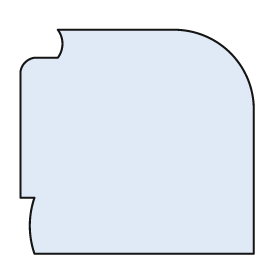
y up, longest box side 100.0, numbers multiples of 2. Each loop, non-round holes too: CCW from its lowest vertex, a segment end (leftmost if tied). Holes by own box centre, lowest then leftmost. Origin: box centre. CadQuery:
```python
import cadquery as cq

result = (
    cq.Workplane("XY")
    .moveTo(-44.0, -48.0)
    .lineTo(50.0, -48.0)
    .lineTo(50.0, 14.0)
    .threePointArc((40.0, 38.0), (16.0, 48.0))
    .lineTo(-34.0, 48.0)
    .threePointArc((-32.0, 42.0), (-34.0, 36.0))
    .lineTo(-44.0, 36.0)
    .threePointArc((-48.0, 34.0), (-50.0, 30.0))
    .lineTo(-50.0, -24.0)
    .lineTo(-44.0, -24.0)
    .threePointArc((-46.0, -36.0), (-44.0, -48.0))
    .close()
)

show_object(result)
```